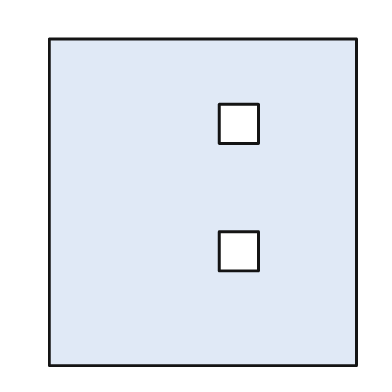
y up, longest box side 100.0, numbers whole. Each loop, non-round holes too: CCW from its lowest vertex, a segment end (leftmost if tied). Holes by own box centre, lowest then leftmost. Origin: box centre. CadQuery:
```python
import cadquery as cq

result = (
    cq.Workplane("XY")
    .moveTo(-47.0, -50.0)
    .lineTo(47.0, -50.0)
    .lineTo(47.0, 50.0)
    .lineTo(-47.0, 50.0)
    .close()
    .moveTo(5.0, -21.0)
    .lineTo(17.0, -21.0)
    .lineTo(17.0, -9.0)
    .lineTo(5.0, -9.0)
    .close()
    .moveTo(5.0, 18.0)
    .lineTo(17.0, 18.0)
    .lineTo(17.0, 30.0)
    .lineTo(5.0, 30.0)
    .close()
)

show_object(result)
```